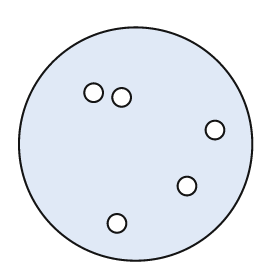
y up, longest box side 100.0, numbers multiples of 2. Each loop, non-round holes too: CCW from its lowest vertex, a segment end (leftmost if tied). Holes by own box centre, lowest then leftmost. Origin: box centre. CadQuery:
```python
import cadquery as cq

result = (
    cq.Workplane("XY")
    .moveTo(0.0, 0.0)
    .circle(50.0)
    .moveTo(-8.0, -34.0)
    .circle(4.0)
    .moveTo(22.0, -18.0)
    .circle(4.0)
    .moveTo(34.0, 6.0)
    .circle(4.0)
    .moveTo(-6.0, 20.0)
    .circle(4.0)
    .moveTo(-18.0, 22.0)
    .circle(4.0)
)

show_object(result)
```